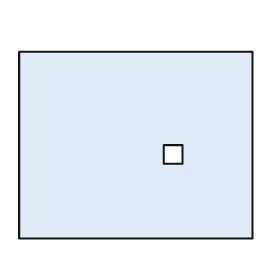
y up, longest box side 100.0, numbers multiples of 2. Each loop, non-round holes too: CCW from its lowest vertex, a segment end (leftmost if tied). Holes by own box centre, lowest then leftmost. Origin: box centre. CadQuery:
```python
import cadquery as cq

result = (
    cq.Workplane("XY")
    .moveTo(-50.0, -40.0)
    .lineTo(50.0, -40.0)
    .lineTo(50.0, 40.0)
    .lineTo(-50.0, 40.0)
    .close()
    .moveTo(12.0, -8.0)
    .lineTo(20.0, -8.0)
    .lineTo(20.0, 0.0)
    .lineTo(12.0, 0.0)
    .close()
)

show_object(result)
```